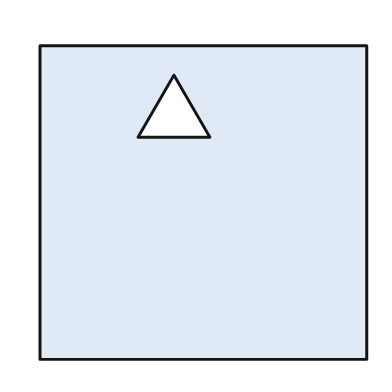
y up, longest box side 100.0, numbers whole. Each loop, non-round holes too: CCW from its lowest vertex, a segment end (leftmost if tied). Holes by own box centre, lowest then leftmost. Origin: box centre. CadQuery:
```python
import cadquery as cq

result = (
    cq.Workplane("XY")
    .moveTo(-50.0, -48.0)
    .lineTo(50.0, -48.0)
    .lineTo(50.0, 48.0)
    .lineTo(-50.0, 48.0)
    .close()
    .moveTo(-20.0, 20.0)
    .lineTo(2.0, 20.0)
    .lineTo(-9.0, 39.0)
    .close()
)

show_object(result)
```